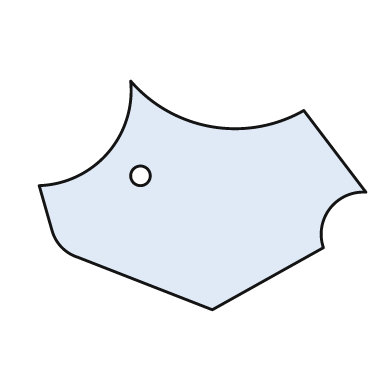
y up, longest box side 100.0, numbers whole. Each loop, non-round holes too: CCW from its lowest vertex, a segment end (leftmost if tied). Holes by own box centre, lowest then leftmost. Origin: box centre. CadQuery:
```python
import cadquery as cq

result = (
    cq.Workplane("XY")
    .moveTo(3.0, -35.0)
    .lineTo(37.0, -16.0)
    .threePointArc((39.0, -4.0), (50.0, 1.0))
    .lineTo(31.0, 26.0)
    .threePointArc((3.0, 21.0), (-22.0, 35.0))
    .threePointArc((-29.0, 13.0), (-50.0, 3.0))
    .lineTo(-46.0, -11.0)
    .threePointArc((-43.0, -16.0), (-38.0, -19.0))
    .close()
    .moveTo(-19.0, 6.0)
    .circle(3.0)
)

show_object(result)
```